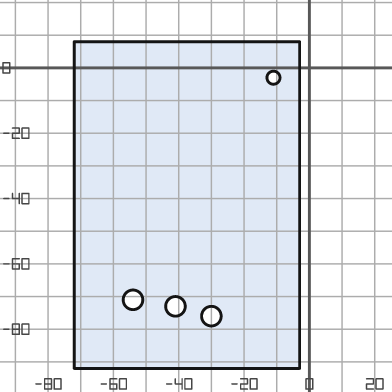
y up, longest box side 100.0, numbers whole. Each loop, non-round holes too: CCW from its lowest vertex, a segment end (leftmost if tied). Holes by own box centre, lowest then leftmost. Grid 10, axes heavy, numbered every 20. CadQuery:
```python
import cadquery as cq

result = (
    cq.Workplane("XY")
    .moveTo(-72.0, -92.0)
    .lineTo(-3.0, -92.0)
    .lineTo(-3.0, 8.0)
    .lineTo(-72.0, 8.0)
    .close()
    .moveTo(-30.0, -76.0)
    .circle(3.0)
    .moveTo(-41.0, -73.0)
    .circle(3.0)
    .moveTo(-54.0, -71.0)
    .circle(3.0)
    .moveTo(-11.0, -3.0)
    .circle(2.0)
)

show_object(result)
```